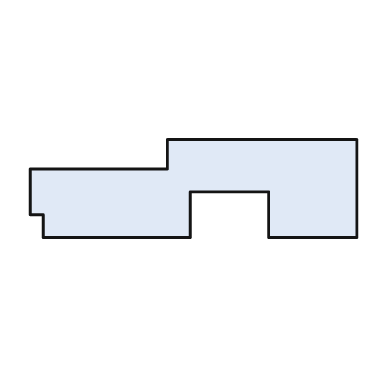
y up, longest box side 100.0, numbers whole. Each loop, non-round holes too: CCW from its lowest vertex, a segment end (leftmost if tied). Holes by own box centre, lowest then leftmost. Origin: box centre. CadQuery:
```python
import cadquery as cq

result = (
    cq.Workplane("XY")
    .moveTo(-46.0, -15.0)
    .lineTo(-1.0, -15.0)
    .lineTo(-1.0, -1.0)
    .lineTo(23.0, -1.0)
    .lineTo(23.0, -15.0)
    .lineTo(50.0, -15.0)
    .lineTo(50.0, 15.0)
    .lineTo(-8.0, 15.0)
    .lineTo(-8.0, 6.0)
    .lineTo(-50.0, 6.0)
    .lineTo(-50.0, -8.0)
    .lineTo(-46.0, -8.0)
    .close()
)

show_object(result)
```